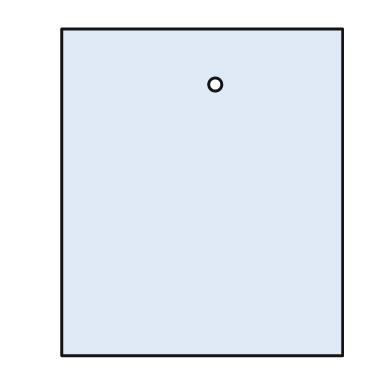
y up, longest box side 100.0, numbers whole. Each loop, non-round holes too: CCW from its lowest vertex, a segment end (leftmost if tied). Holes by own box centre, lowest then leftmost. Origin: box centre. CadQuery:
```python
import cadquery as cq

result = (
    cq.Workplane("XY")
    .moveTo(-43.0, -50.0)
    .lineTo(43.0, -50.0)
    .lineTo(43.0, 50.0)
    .lineTo(-43.0, 50.0)
    .close()
    .moveTo(4.0, 33.0)
    .circle(2.0)
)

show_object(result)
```